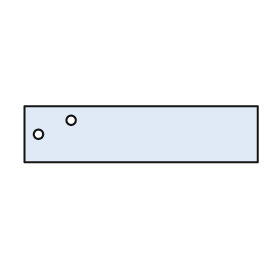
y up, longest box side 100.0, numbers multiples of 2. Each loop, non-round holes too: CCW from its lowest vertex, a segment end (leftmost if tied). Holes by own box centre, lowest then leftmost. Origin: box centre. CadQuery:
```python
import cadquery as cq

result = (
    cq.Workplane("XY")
    .moveTo(-50.0, -12.0)
    .lineTo(50.0, -12.0)
    .lineTo(50.0, 12.0)
    .lineTo(-50.0, 12.0)
    .close()
    .moveTo(-44.0, 0.0)
    .circle(2.0)
    .moveTo(-30.0, 6.0)
    .circle(2.0)
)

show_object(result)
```